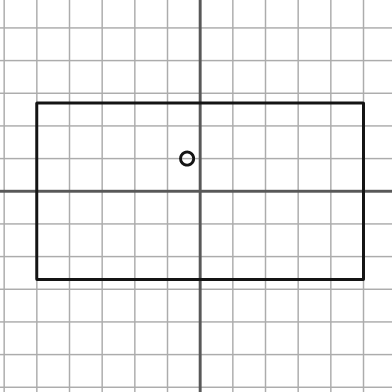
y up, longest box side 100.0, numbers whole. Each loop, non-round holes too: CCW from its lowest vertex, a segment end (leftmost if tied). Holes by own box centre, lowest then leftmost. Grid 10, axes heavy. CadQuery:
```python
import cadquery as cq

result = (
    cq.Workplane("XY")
    .moveTo(-50.0, -27.0)
    .lineTo(50.0, -27.0)
    .lineTo(50.0, 27.0)
    .lineTo(-50.0, 27.0)
    .close()
    .moveTo(-4.0, 10.0)
    .circle(2.0)
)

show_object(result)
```